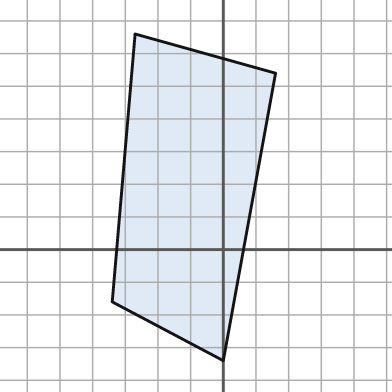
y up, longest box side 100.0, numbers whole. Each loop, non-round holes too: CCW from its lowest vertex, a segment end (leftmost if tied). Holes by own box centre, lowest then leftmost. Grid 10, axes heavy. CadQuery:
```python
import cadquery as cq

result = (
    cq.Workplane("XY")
    .moveTo(0.0, -34.0)
    .lineTo(16.0, 54.0)
    .lineTo(-27.0, 66.0)
    .lineTo(-34.0, -16.0)
    .close()
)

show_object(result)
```